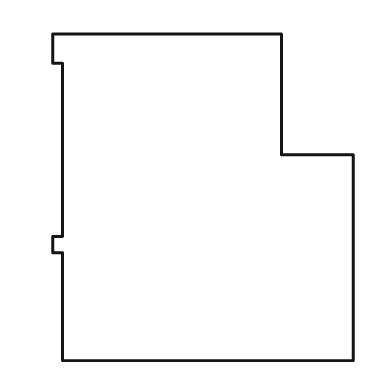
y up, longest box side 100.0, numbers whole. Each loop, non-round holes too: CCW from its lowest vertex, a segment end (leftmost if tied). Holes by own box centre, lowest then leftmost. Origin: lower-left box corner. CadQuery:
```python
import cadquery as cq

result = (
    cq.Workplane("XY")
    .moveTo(3.0, 0.0)
    .lineTo(92.0, 0.0)
    .lineTo(92.0, 63.0)
    .lineTo(70.0, 63.0)
    .lineTo(70.0, 100.0)
    .lineTo(0.0, 100.0)
    .lineTo(0.0, 91.0)
    .lineTo(3.0, 91.0)
    .lineTo(3.0, 38.0)
    .lineTo(0.0, 38.0)
    .lineTo(0.0, 33.0)
    .lineTo(3.0, 33.0)
    .close()
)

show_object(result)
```